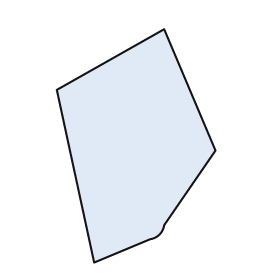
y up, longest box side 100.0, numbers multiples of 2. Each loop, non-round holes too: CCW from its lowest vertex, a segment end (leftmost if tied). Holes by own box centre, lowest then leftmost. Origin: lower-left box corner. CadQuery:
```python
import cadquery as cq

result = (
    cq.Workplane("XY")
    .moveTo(16.0, 0.0)
    .lineTo(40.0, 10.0)
    .threePointArc((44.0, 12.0), (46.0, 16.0))
    .lineTo(68.0, 48.0)
    .lineTo(46.0, 100.0)
    .lineTo(0.0, 74.0)
    .close()
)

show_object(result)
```